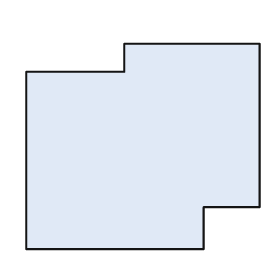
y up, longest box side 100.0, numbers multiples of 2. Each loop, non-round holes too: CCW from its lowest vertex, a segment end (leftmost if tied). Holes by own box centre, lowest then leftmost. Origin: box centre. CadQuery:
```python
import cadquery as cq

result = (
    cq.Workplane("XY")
    .moveTo(-50.0, -44.0)
    .lineTo(26.0, -44.0)
    .lineTo(26.0, -26.0)
    .lineTo(50.0, -26.0)
    .lineTo(50.0, 44.0)
    .lineTo(-8.0, 44.0)
    .lineTo(-8.0, 32.0)
    .lineTo(-50.0, 32.0)
    .close()
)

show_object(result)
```